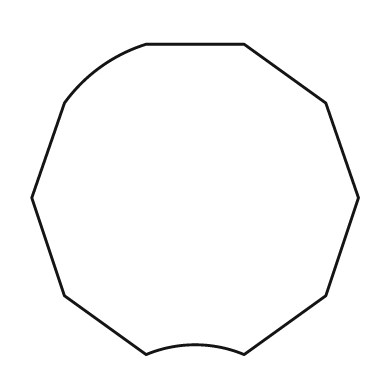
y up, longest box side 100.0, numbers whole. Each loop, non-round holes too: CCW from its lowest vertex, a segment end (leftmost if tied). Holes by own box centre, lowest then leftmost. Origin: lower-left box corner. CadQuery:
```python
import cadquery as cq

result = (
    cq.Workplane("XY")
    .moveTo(35.0, 0.0)
    .threePointArc((50.0, 3.0), (65.0, 0.0))
    .lineTo(90.0, 18.0)
    .lineTo(100.0, 48.0)
    .lineTo(90.0, 77.0)
    .lineTo(65.0, 95.0)
    .lineTo(35.0, 95.0)
    .threePointArc((21.0, 88.0), (10.0, 77.0))
    .lineTo(0.0, 48.0)
    .lineTo(10.0, 18.0)
    .close()
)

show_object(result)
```